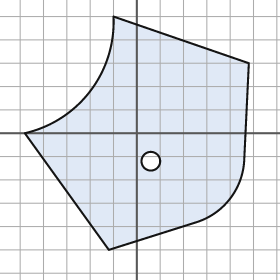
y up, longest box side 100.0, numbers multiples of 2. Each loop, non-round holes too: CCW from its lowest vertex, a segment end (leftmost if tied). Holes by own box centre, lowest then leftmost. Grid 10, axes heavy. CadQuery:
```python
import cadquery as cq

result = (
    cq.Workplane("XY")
    .moveTo(-12.0, -50.0)
    .lineTo(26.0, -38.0)
    .threePointArc((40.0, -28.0), (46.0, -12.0))
    .lineTo(48.0, 30.0)
    .lineTo(-10.0, 50.0)
    .threePointArc((-20.0, 18.0), (-48.0, 0.0))
    .close()
    .moveTo(6.0, -12.0)
    .circle(4.0)
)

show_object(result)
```